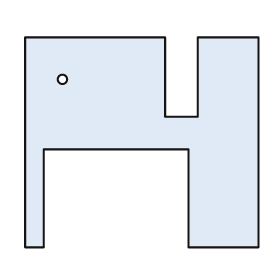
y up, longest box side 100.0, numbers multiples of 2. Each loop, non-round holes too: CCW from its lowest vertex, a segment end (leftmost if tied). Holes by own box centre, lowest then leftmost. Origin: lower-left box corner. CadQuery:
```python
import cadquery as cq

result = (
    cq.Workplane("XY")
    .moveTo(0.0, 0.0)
    .lineTo(8.0, 0.0)
    .lineTo(8.0, 42.0)
    .lineTo(70.0, 42.0)
    .lineTo(70.0, 0.0)
    .lineTo(100.0, 0.0)
    .lineTo(100.0, 90.0)
    .lineTo(74.0, 90.0)
    .lineTo(74.0, 56.0)
    .lineTo(60.0, 56.0)
    .lineTo(60.0, 90.0)
    .lineTo(0.0, 90.0)
    .close()
    .moveTo(16.0, 72.0)
    .circle(2.0)
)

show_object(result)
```